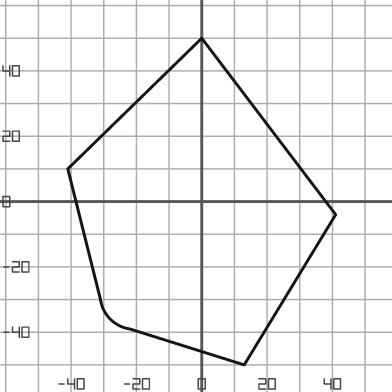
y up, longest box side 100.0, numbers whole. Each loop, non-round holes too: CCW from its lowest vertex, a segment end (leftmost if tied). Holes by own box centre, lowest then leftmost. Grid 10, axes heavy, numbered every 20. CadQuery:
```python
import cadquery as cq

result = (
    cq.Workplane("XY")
    .moveTo(13.0, -50.0)
    .lineTo(41.0, -4.0)
    .lineTo(0.0, 50.0)
    .lineTo(-41.0, 10.0)
    .lineTo(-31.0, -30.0)
    .threePointArc((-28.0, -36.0), (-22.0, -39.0))
    .close()
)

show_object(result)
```